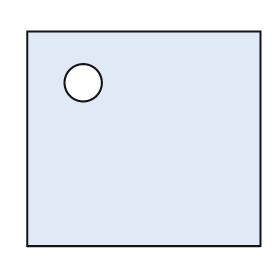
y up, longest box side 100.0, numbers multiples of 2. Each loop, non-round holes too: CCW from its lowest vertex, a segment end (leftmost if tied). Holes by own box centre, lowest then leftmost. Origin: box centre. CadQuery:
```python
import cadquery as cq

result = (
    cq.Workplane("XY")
    .moveTo(-50.0, -46.0)
    .lineTo(50.0, -46.0)
    .lineTo(50.0, 46.0)
    .lineTo(-50.0, 46.0)
    .close()
    .moveTo(-26.0, 24.0)
    .circle(8.0)
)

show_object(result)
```